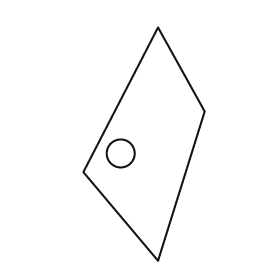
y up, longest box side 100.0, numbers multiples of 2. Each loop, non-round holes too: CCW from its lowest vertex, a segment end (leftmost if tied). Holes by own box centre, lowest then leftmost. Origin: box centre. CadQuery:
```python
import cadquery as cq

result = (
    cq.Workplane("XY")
    .moveTo(6.0, -50.0)
    .lineTo(26.0, 14.0)
    .lineTo(6.0, 50.0)
    .lineTo(-26.0, -12.0)
    .close()
    .moveTo(-10.0, -4.0)
    .circle(6.0)
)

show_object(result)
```